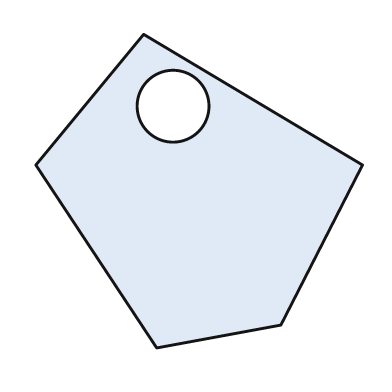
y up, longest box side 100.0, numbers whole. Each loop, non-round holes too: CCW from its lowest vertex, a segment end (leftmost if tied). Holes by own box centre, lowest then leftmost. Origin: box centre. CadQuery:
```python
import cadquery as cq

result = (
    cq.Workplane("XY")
    .moveTo(-13.0, -48.0)
    .lineTo(25.0, -41.0)
    .lineTo(50.0, 8.0)
    .lineTo(-17.0, 48.0)
    .lineTo(-50.0, 8.0)
    .close()
    .moveTo(-8.0, 26.0)
    .circle(11.0)
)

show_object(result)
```